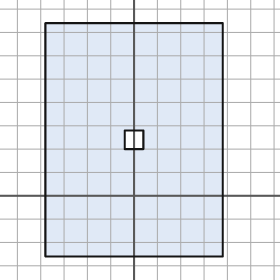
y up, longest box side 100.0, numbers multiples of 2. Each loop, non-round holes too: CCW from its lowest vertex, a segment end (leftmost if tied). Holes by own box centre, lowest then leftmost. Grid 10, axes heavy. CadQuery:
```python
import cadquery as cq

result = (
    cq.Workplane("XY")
    .moveTo(-38.0, -26.0)
    .lineTo(38.0, -26.0)
    .lineTo(38.0, 74.0)
    .lineTo(-38.0, 74.0)
    .close()
    .moveTo(-4.0, 20.0)
    .lineTo(4.0, 20.0)
    .lineTo(4.0, 28.0)
    .lineTo(-4.0, 28.0)
    .close()
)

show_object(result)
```